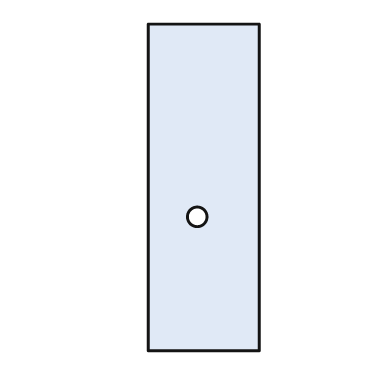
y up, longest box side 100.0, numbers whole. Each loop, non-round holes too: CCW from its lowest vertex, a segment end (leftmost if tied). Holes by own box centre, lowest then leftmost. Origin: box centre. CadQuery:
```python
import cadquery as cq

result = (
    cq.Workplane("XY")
    .moveTo(-17.0, -50.0)
    .lineTo(17.0, -50.0)
    .lineTo(17.0, 50.0)
    .lineTo(-17.0, 50.0)
    .close()
    .moveTo(-2.0, -9.0)
    .circle(3.0)
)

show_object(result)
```